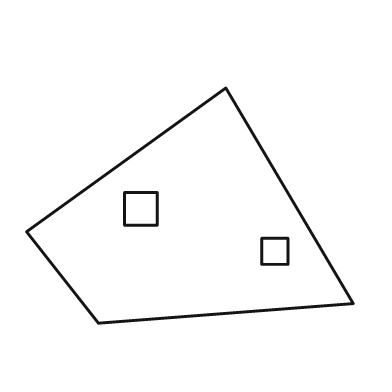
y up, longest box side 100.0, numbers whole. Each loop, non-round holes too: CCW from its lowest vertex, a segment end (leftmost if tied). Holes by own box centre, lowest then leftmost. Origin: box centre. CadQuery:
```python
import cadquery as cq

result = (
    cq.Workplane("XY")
    .moveTo(-28.0, -36.0)
    .lineTo(50.0, -30.0)
    .lineTo(11.0, 36.0)
    .lineTo(-50.0, -8.0)
    .close()
    .moveTo(22.0, -18.0)
    .lineTo(30.0, -18.0)
    .lineTo(30.0, -10.0)
    .lineTo(22.0, -10.0)
    .close()
    .moveTo(-20.0, -6.0)
    .lineTo(-10.0, -6.0)
    .lineTo(-10.0, 4.0)
    .lineTo(-20.0, 4.0)
    .close()
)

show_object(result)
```